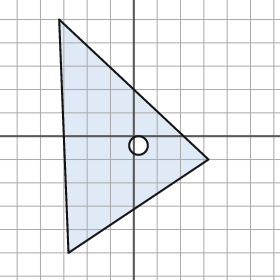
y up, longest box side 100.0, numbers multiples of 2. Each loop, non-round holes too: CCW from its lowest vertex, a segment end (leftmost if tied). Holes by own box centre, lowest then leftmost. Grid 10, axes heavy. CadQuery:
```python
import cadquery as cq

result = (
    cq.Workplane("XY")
    .moveTo(-28.0, -50.0)
    .lineTo(32.0, -10.0)
    .lineTo(-32.0, 50.0)
    .close()
    .moveTo(2.0, -4.0)
    .circle(4.0)
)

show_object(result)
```